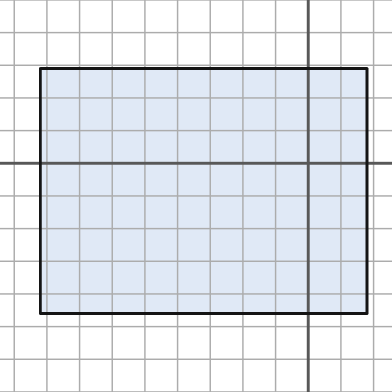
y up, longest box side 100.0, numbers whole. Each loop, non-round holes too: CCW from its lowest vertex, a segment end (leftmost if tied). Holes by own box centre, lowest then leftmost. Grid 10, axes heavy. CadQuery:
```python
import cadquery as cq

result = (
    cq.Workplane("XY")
    .moveTo(-82.0, -46.0)
    .lineTo(18.0, -46.0)
    .lineTo(18.0, 29.0)
    .lineTo(-82.0, 29.0)
    .close()
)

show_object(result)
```